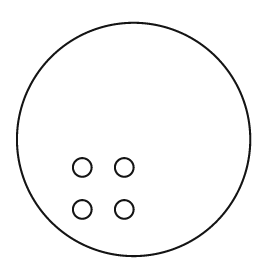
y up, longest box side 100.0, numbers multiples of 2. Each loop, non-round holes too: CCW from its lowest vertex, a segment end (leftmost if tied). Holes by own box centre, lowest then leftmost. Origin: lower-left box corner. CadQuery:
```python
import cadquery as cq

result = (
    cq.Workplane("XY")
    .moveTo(50.0, 50.0)
    .circle(50.0)
    .moveTo(28.0, 20.0)
    .circle(4.0)
    .moveTo(46.0, 20.0)
    .circle(4.0)
    .moveTo(28.0, 38.0)
    .circle(4.0)
    .moveTo(46.0, 38.0)
    .circle(4.0)
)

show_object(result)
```